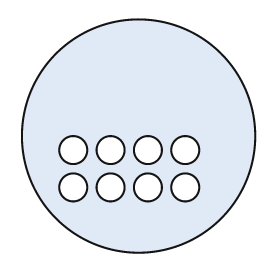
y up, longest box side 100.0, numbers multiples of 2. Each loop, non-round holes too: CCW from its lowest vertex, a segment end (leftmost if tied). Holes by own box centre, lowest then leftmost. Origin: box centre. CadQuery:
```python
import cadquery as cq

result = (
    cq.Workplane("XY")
    .moveTo(0.0, 0.0)
    .circle(50.0)
    .moveTo(-28.0, -22.0)
    .circle(6.0)
    .moveTo(-12.0, -22.0)
    .circle(6.0)
    .moveTo(4.0, -22.0)
    .circle(6.0)
    .moveTo(20.0, -22.0)
    .circle(6.0)
    .moveTo(-28.0, -6.0)
    .circle(6.0)
    .moveTo(-12.0, -6.0)
    .circle(6.0)
    .moveTo(4.0, -6.0)
    .circle(6.0)
    .moveTo(20.0, -6.0)
    .circle(6.0)
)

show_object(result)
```